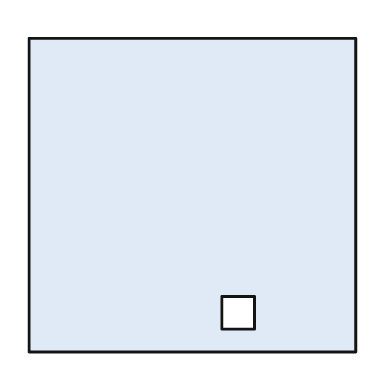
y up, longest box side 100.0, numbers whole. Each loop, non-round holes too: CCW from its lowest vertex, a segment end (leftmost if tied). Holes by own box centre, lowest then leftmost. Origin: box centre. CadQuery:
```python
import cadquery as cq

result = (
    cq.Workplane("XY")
    .moveTo(-50.0, -48.0)
    .lineTo(50.0, -48.0)
    .lineTo(50.0, 48.0)
    .lineTo(-50.0, 48.0)
    .close()
    .moveTo(9.0, -41.0)
    .lineTo(19.0, -41.0)
    .lineTo(19.0, -31.0)
    .lineTo(9.0, -31.0)
    .close()
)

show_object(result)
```